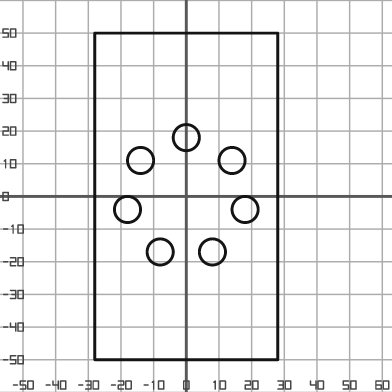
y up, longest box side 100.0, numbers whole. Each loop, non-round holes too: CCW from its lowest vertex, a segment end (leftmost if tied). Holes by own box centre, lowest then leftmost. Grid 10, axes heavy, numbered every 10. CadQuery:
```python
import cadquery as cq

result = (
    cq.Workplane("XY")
    .moveTo(-28.0, -50.0)
    .lineTo(28.0, -50.0)
    .lineTo(28.0, 50.0)
    .lineTo(-28.0, 50.0)
    .close()
    .moveTo(-8.0, -17.0)
    .circle(4.0)
    .moveTo(8.0, -17.0)
    .circle(4.0)
    .moveTo(-18.0, -4.0)
    .circle(4.0)
    .moveTo(18.0, -4.0)
    .circle(4.0)
    .moveTo(-14.0, 11.0)
    .circle(4.0)
    .moveTo(14.0, 11.0)
    .circle(4.0)
    .moveTo(0.0, 18.0)
    .circle(4.0)
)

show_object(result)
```